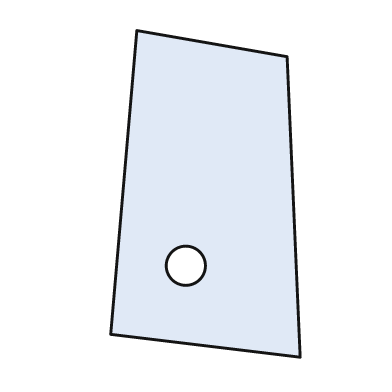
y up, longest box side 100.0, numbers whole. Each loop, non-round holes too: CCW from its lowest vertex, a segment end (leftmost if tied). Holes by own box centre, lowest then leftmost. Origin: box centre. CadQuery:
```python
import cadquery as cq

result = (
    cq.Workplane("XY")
    .moveTo(29.0, -50.0)
    .lineTo(25.0, 42.0)
    .lineTo(-21.0, 50.0)
    .lineTo(-29.0, -43.0)
    .close()
    .moveTo(-6.0, -22.0)
    .circle(6.0)
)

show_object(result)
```